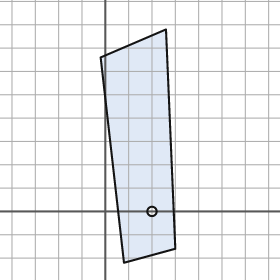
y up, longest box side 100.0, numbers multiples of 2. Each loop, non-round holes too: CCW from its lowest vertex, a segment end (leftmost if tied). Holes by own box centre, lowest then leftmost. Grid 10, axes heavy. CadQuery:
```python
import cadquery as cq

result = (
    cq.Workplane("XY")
    .moveTo(8.0, -22.0)
    .lineTo(30.0, -16.0)
    .lineTo(26.0, 78.0)
    .lineTo(-2.0, 66.0)
    .close()
    .moveTo(20.0, 0.0)
    .circle(2.0)
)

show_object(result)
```